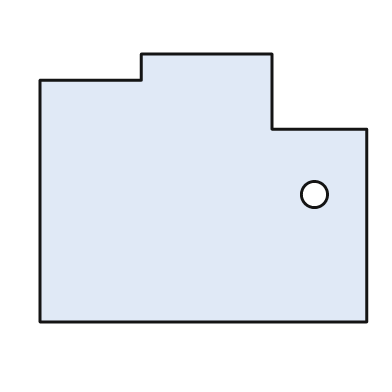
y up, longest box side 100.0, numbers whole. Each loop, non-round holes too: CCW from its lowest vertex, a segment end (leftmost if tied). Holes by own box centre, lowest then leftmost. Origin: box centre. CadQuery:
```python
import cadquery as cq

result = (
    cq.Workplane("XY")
    .moveTo(-50.0, -41.0)
    .lineTo(50.0, -41.0)
    .lineTo(50.0, 18.0)
    .lineTo(21.0, 18.0)
    .lineTo(21.0, 41.0)
    .lineTo(-19.0, 41.0)
    .lineTo(-19.0, 33.0)
    .lineTo(-50.0, 33.0)
    .close()
    .moveTo(34.0, -2.0)
    .circle(4.0)
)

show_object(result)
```